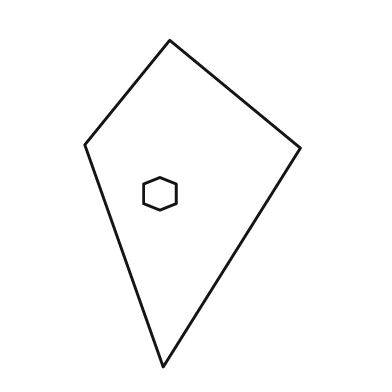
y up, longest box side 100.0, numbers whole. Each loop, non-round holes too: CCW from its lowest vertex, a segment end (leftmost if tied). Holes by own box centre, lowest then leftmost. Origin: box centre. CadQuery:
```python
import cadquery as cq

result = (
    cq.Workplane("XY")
    .moveTo(-9.0, -50.0)
    .lineTo(33.0, 17.0)
    .lineTo(-7.0, 50.0)
    .lineTo(-33.0, 18.0)
    .close()
    .moveTo(-10.0, -2.0)
    .lineTo(-5.0, 0.0)
    .lineTo(-5.0, 6.0)
    .lineTo(-10.0, 8.0)
    .lineTo(-15.0, 6.0)
    .lineTo(-15.0, 0.0)
    .close()
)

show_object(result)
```